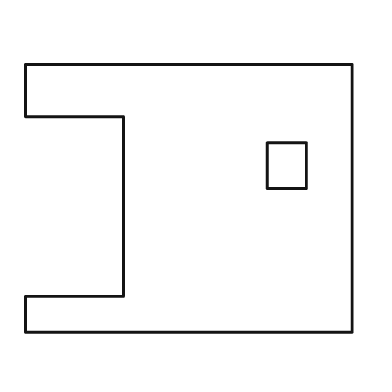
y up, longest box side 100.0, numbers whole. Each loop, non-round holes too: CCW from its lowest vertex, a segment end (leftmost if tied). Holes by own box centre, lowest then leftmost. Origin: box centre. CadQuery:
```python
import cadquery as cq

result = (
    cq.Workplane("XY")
    .moveTo(-50.0, -41.0)
    .lineTo(50.0, -41.0)
    .lineTo(50.0, 41.0)
    .lineTo(-50.0, 41.0)
    .lineTo(-50.0, 25.0)
    .lineTo(-20.0, 25.0)
    .lineTo(-20.0, -30.0)
    .lineTo(-50.0, -30.0)
    .close()
    .moveTo(24.0, 3.0)
    .lineTo(36.0, 3.0)
    .lineTo(36.0, 17.0)
    .lineTo(24.0, 17.0)
    .close()
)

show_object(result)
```